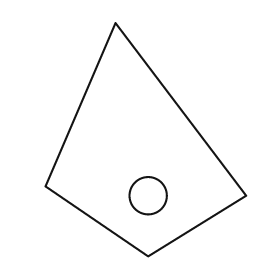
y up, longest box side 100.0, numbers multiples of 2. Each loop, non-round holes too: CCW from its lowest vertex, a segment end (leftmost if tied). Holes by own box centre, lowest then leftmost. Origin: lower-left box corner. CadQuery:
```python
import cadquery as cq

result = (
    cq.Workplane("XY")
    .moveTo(44.0, 0.0)
    .lineTo(86.0, 26.0)
    .lineTo(30.0, 100.0)
    .lineTo(0.0, 30.0)
    .close()
    .moveTo(44.0, 26.0)
    .circle(8.0)
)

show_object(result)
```